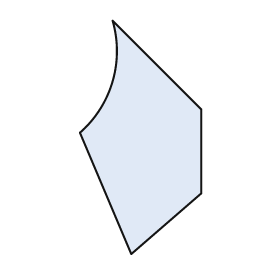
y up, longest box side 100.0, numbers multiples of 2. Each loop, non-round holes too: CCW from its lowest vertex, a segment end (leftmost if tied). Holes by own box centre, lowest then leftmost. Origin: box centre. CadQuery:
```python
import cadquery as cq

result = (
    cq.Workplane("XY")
    .moveTo(-4.0, -50.0)
    .lineTo(26.0, -24.0)
    .lineTo(26.0, 12.0)
    .lineTo(-12.0, 50.0)
    .threePointArc((-12.0, 24.0), (-26.0, 2.0))
    .close()
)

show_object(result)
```